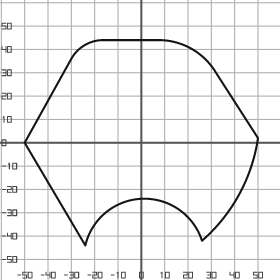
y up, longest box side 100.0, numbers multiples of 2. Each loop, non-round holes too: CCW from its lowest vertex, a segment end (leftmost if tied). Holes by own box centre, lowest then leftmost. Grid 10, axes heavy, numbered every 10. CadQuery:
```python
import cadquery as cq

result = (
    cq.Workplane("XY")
    .moveTo(-24.0, -44.0)
    .threePointArc((0.0, -24.0), (26.0, -42.0))
    .threePointArc((42.0, -22.0), (50.0, 2.0))
    .lineTo(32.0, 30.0)
    .threePointArc((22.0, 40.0), (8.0, 44.0))
    .lineTo(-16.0, 44.0)
    .threePointArc((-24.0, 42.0), (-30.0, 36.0))
    .lineTo(-50.0, 0.0)
    .close()
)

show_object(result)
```